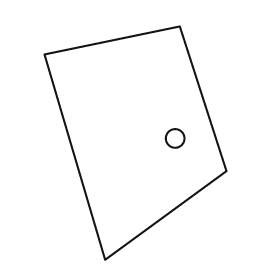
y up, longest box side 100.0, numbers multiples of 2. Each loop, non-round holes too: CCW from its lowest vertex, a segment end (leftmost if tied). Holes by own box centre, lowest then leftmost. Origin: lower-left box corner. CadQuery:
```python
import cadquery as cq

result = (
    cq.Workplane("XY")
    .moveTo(26.0, 0.0)
    .lineTo(78.0, 38.0)
    .lineTo(58.0, 100.0)
    .lineTo(0.0, 88.0)
    .close()
    .moveTo(56.0, 52.0)
    .circle(4.0)
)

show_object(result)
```